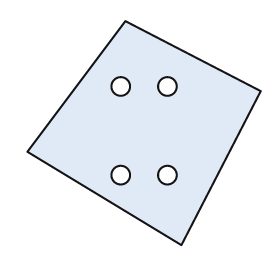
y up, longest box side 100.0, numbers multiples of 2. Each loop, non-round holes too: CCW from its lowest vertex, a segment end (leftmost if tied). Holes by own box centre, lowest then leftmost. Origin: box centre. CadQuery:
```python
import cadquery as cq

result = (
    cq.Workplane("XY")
    .moveTo(16.0, -48.0)
    .lineTo(50.0, 18.0)
    .lineTo(-8.0, 48.0)
    .lineTo(-50.0, -8.0)
    .close()
    .moveTo(-10.0, -18.0)
    .circle(4.0)
    .moveTo(10.0, -18.0)
    .circle(4.0)
    .moveTo(-10.0, 20.0)
    .circle(4.0)
    .moveTo(10.0, 20.0)
    .circle(4.0)
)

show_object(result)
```